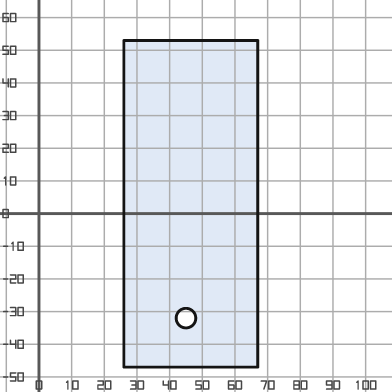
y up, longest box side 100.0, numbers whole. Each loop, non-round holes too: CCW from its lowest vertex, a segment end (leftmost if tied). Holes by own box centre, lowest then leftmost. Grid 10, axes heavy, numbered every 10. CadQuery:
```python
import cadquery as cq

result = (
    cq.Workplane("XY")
    .moveTo(26.0, -47.0)
    .lineTo(67.0, -47.0)
    .lineTo(67.0, 53.0)
    .lineTo(26.0, 53.0)
    .close()
    .moveTo(45.0, -32.0)
    .circle(3.0)
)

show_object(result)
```